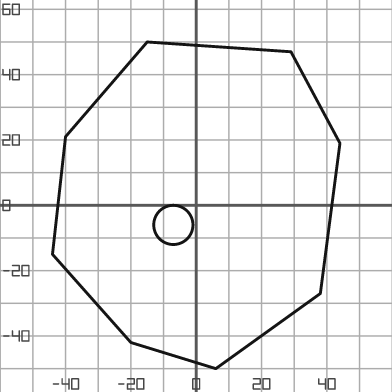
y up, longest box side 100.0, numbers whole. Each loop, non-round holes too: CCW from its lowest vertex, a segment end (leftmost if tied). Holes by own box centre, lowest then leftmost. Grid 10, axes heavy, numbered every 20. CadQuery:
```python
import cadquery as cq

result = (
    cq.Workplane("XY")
    .moveTo(6.0, -50.0)
    .lineTo(38.0, -27.0)
    .lineTo(44.0, 19.0)
    .lineTo(29.0, 47.0)
    .lineTo(-15.0, 50.0)
    .lineTo(-40.0, 21.0)
    .lineTo(-44.0, -15.0)
    .lineTo(-20.0, -42.0)
    .close()
    .moveTo(-7.0, -6.0)
    .circle(6.0)
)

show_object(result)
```